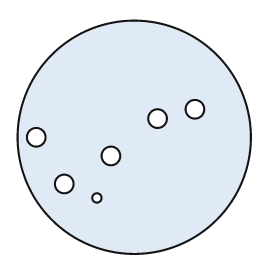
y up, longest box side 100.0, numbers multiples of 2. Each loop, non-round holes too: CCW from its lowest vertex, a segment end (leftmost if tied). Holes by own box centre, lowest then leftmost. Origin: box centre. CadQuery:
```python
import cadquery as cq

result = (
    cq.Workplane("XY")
    .moveTo(0.0, 0.0)
    .circle(50.0)
    .moveTo(-16.0, -26.0)
    .circle(2.0)
    .moveTo(-30.0, -20.0)
    .circle(4.0)
    .moveTo(-10.0, -8.0)
    .circle(4.0)
    .moveTo(-42.0, 0.0)
    .circle(4.0)
    .moveTo(10.0, 8.0)
    .circle(4.0)
    .moveTo(26.0, 12.0)
    .circle(4.0)
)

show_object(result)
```